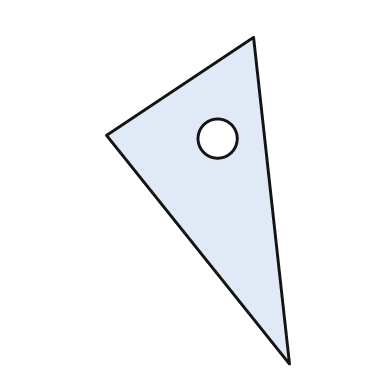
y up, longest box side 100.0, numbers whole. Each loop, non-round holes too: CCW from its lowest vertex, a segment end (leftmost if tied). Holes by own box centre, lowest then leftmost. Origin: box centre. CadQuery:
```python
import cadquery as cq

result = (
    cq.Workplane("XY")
    .moveTo(28.0, -50.0)
    .lineTo(17.0, 50.0)
    .lineTo(-28.0, 20.0)
    .close()
    .moveTo(6.0, 19.0)
    .circle(6.0)
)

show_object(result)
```